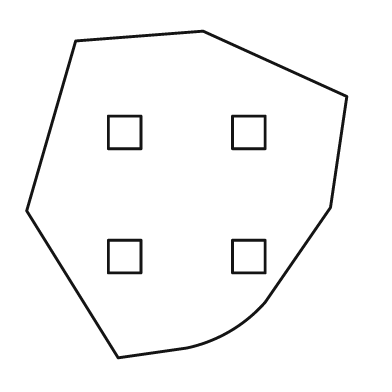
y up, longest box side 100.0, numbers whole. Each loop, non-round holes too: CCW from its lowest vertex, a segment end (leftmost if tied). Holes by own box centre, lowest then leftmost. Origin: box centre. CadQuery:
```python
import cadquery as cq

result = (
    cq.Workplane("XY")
    .moveTo(-21.0, -50.0)
    .lineTo(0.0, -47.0)
    .threePointArc((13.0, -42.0), (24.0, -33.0))
    .lineTo(44.0, -4.0)
    .lineTo(49.0, 30.0)
    .lineTo(5.0, 50.0)
    .lineTo(-34.0, 47.0)
    .lineTo(-49.0, -5.0)
    .close()
    .moveTo(-24.0, -24.0)
    .lineTo(-14.0, -24.0)
    .lineTo(-14.0, -14.0)
    .lineTo(-24.0, -14.0)
    .close()
    .moveTo(14.0, -24.0)
    .lineTo(24.0, -24.0)
    .lineTo(24.0, -14.0)
    .lineTo(14.0, -14.0)
    .close()
    .moveTo(-24.0, 14.0)
    .lineTo(-14.0, 14.0)
    .lineTo(-14.0, 24.0)
    .lineTo(-24.0, 24.0)
    .close()
    .moveTo(14.0, 14.0)
    .lineTo(24.0, 14.0)
    .lineTo(24.0, 24.0)
    .lineTo(14.0, 24.0)
    .close()
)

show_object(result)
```